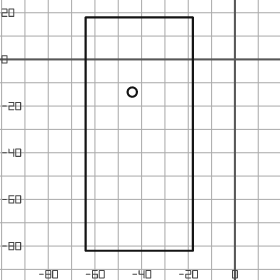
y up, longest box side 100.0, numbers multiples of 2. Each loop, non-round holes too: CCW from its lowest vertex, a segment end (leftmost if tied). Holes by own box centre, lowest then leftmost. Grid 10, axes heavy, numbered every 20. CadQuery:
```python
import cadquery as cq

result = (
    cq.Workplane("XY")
    .moveTo(-64.0, -82.0)
    .lineTo(-18.0, -82.0)
    .lineTo(-18.0, 18.0)
    .lineTo(-64.0, 18.0)
    .close()
    .moveTo(-44.0, -14.0)
    .circle(2.0)
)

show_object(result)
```